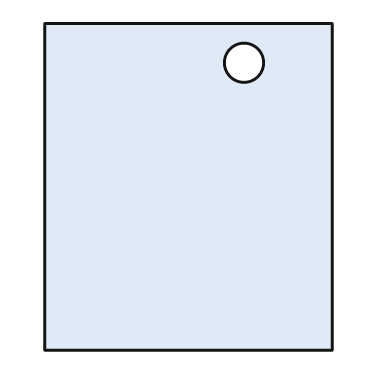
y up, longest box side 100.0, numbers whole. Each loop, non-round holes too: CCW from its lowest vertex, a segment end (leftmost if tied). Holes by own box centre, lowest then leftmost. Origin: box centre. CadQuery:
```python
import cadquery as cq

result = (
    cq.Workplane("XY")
    .moveTo(-44.0, -50.0)
    .lineTo(44.0, -50.0)
    .lineTo(44.0, 50.0)
    .lineTo(-44.0, 50.0)
    .close()
    .moveTo(17.0, 38.0)
    .circle(6.0)
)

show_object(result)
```